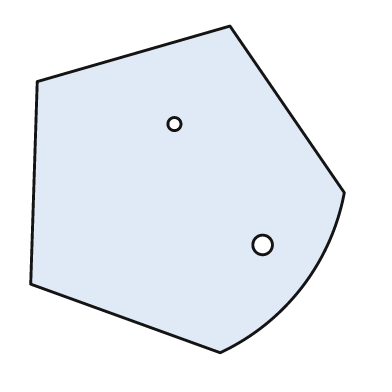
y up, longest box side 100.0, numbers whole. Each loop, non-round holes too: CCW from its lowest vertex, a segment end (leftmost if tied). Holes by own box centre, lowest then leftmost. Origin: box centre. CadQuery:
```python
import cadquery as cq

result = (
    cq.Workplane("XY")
    .moveTo(10.0, -50.0)
    .threePointArc((35.0, -30.0), (48.0, -1.0))
    .lineTo(13.0, 50.0)
    .lineTo(-46.0, 33.0)
    .lineTo(-48.0, -29.0)
    .close()
    .moveTo(23.0, -17.0)
    .circle(3.0)
    .moveTo(-4.0, 20.0)
    .circle(2.0)
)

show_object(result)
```